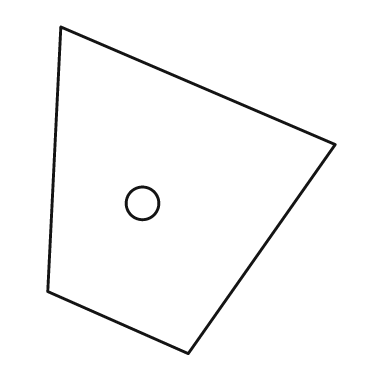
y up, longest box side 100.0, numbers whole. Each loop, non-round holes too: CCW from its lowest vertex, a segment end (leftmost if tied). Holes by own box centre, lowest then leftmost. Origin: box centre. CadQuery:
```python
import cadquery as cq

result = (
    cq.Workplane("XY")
    .moveTo(-1.0, -50.0)
    .lineTo(44.0, 14.0)
    .lineTo(-40.0, 50.0)
    .lineTo(-44.0, -31.0)
    .close()
    .moveTo(-15.0, -4.0)
    .circle(5.0)
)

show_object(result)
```